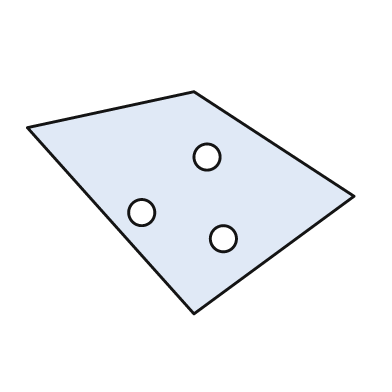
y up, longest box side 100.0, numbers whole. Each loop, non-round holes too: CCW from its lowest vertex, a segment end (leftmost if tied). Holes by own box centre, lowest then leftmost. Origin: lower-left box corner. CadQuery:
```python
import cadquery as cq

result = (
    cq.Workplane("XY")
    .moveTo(51.0, 0.0)
    .lineTo(100.0, 36.0)
    .lineTo(51.0, 68.0)
    .lineTo(0.0, 57.0)
    .close()
    .moveTo(60.0, 23.0)
    .circle(4.0)
    .moveTo(35.0, 31.0)
    .circle(4.0)
    .moveTo(55.0, 48.0)
    .circle(4.0)
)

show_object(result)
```